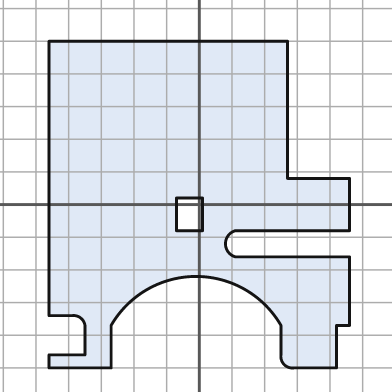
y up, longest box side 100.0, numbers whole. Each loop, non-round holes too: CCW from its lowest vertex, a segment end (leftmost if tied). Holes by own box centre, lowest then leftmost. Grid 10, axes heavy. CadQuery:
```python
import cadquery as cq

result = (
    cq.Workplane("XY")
    .moveTo(-46.0, -50.0)
    .lineTo(-27.0, -50.0)
    .lineTo(-27.0, -37.0)
    .threePointArc((-1.0, -22.0), (25.0, -37.0))
    .lineTo(25.0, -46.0)
    .threePointArc((26.0, -49.0), (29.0, -50.0))
    .lineTo(42.0, -50.0)
    .lineTo(42.0, -37.0)
    .lineTo(46.0, -37.0)
    .lineTo(46.0, -16.0)
    .lineTo(11.0, -16.0)
    .threePointArc((8.0, -12.0), (11.0, -8.0))
    .lineTo(46.0, -8.0)
    .lineTo(46.0, 8.0)
    .lineTo(27.0, 8.0)
    .lineTo(27.0, 50.0)
    .lineTo(-46.0, 50.0)
    .lineTo(-46.0, -34.0)
    .lineTo(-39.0, -34.0)
    .threePointArc((-36.0, -35.0), (-35.0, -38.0))
    .lineTo(-35.0, -46.0)
    .lineTo(-46.0, -46.0)
    .close()
    .moveTo(-7.0, -8.0)
    .lineTo(1.0, -8.0)
    .lineTo(1.0, 2.0)
    .lineTo(-7.0, 2.0)
    .close()
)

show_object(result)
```